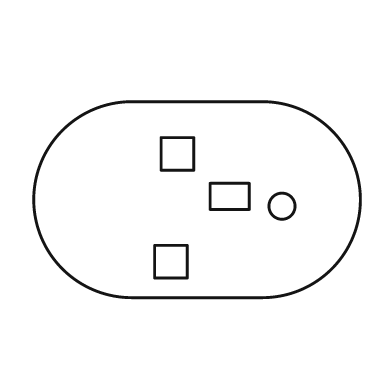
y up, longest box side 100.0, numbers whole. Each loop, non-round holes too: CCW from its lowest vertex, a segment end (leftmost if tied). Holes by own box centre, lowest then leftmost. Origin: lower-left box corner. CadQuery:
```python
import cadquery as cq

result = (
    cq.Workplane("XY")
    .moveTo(30.0, 0.0)
    .lineTo(70.0, 0.0)
    .threePointArc((100.0, 30.0), (70.0, 60.0))
    .lineTo(30.0, 60.0)
    .threePointArc((0.0, 30.0), (30.0, 0.0))
    .close()
    .moveTo(37.0, 6.0)
    .lineTo(47.0, 6.0)
    .lineTo(47.0, 16.0)
    .lineTo(37.0, 16.0)
    .close()
    .moveTo(76.0, 28.0)
    .circle(4.0)
    .moveTo(54.0, 27.0)
    .lineTo(66.0, 27.0)
    .lineTo(66.0, 35.0)
    .lineTo(54.0, 35.0)
    .close()
    .moveTo(39.0, 39.0)
    .lineTo(49.0, 39.0)
    .lineTo(49.0, 49.0)
    .lineTo(39.0, 49.0)
    .close()
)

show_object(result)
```